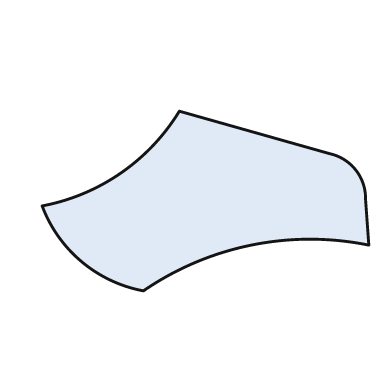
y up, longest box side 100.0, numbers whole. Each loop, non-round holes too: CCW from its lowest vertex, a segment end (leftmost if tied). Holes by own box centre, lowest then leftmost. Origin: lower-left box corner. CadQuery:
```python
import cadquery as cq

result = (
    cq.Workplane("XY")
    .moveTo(31.0, 0.0)
    .threePointArc((64.0, 14.0), (100.0, 14.0))
    .lineTo(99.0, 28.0)
    .threePointArc((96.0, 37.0), (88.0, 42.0))
    .lineTo(42.0, 55.0)
    .threePointArc((24.0, 36.0), (0.0, 26.0))
    .threePointArc((12.0, 9.0), (31.0, 0.0))
    .close()
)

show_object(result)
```